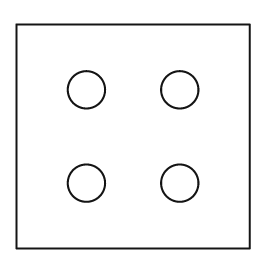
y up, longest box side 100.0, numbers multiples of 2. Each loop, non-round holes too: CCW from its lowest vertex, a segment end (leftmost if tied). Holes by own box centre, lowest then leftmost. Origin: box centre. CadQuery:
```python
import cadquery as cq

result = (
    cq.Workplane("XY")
    .moveTo(-50.0, -48.0)
    .lineTo(50.0, -48.0)
    .lineTo(50.0, 48.0)
    .lineTo(-50.0, 48.0)
    .close()
    .moveTo(-20.0, -20.0)
    .circle(8.0)
    .moveTo(20.0, -20.0)
    .circle(8.0)
    .moveTo(-20.0, 20.0)
    .circle(8.0)
    .moveTo(20.0, 20.0)
    .circle(8.0)
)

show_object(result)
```